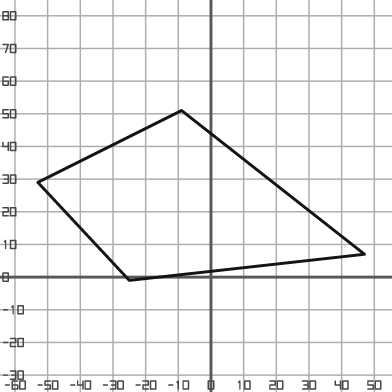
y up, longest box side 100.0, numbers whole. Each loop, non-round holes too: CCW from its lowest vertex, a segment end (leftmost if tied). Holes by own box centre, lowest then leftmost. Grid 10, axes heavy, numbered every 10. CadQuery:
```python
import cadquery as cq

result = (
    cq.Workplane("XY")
    .moveTo(-25.0, -1.0)
    .lineTo(47.0, 7.0)
    .lineTo(-9.0, 51.0)
    .lineTo(-53.0, 29.0)
    .close()
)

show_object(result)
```